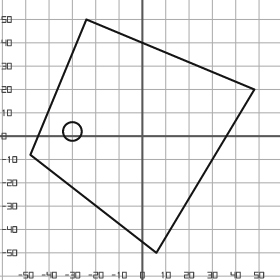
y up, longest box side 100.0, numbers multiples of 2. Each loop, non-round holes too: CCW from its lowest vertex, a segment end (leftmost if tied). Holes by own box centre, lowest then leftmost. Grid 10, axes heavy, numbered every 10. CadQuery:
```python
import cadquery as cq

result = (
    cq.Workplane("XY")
    .moveTo(6.0, -50.0)
    .lineTo(48.0, 20.0)
    .lineTo(-24.0, 50.0)
    .lineTo(-48.0, -8.0)
    .close()
    .moveTo(-30.0, 2.0)
    .circle(4.0)
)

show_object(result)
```